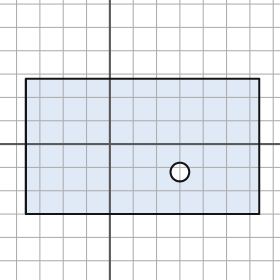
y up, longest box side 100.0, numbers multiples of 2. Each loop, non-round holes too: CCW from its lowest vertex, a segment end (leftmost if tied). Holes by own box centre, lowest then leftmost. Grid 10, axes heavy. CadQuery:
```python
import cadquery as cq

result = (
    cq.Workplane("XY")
    .moveTo(-36.0, -30.0)
    .lineTo(64.0, -30.0)
    .lineTo(64.0, 28.0)
    .lineTo(-36.0, 28.0)
    .close()
    .moveTo(30.0, -12.0)
    .circle(4.0)
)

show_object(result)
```